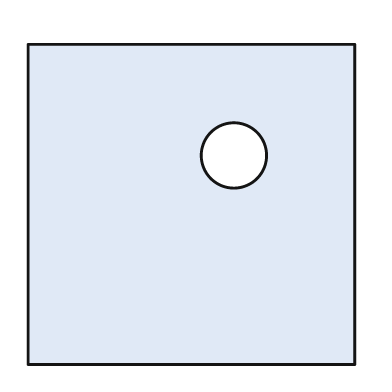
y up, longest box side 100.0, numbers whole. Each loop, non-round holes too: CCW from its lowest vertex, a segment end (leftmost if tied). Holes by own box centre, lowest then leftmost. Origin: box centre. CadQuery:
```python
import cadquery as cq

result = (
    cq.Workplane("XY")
    .moveTo(-50.0, -49.0)
    .lineTo(50.0, -49.0)
    .lineTo(50.0, 49.0)
    .lineTo(-50.0, 49.0)
    .close()
    .moveTo(13.0, 15.0)
    .circle(10.0)
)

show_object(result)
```